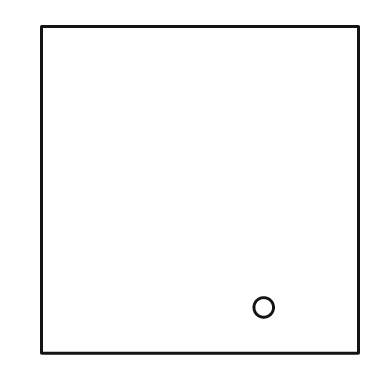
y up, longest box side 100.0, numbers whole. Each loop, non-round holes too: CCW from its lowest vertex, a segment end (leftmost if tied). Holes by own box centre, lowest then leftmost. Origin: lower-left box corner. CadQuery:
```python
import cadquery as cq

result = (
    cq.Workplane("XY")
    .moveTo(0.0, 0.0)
    .lineTo(97.0, 0.0)
    .lineTo(97.0, 100.0)
    .lineTo(0.0, 100.0)
    .close()
    .moveTo(68.0, 14.0)
    .circle(3.0)
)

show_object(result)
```